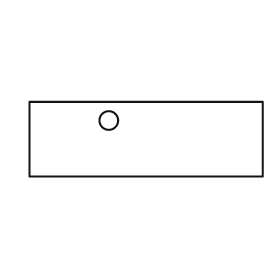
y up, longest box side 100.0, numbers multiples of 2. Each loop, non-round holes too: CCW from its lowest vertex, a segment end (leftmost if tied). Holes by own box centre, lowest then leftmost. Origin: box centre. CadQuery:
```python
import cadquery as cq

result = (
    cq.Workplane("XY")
    .moveTo(-50.0, -16.0)
    .lineTo(50.0, -16.0)
    .lineTo(50.0, 16.0)
    .lineTo(-50.0, 16.0)
    .close()
    .moveTo(-16.0, 8.0)
    .circle(4.0)
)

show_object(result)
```